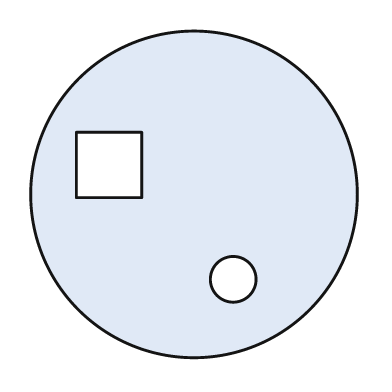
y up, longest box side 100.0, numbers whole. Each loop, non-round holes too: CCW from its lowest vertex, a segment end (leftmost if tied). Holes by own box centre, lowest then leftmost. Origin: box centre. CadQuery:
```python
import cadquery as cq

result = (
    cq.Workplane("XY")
    .moveTo(0.0, 0.0)
    .circle(50.0)
    .moveTo(12.0, -26.0)
    .circle(7.0)
    .moveTo(-36.0, -1.0)
    .lineTo(-16.0, -1.0)
    .lineTo(-16.0, 19.0)
    .lineTo(-36.0, 19.0)
    .close()
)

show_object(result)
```